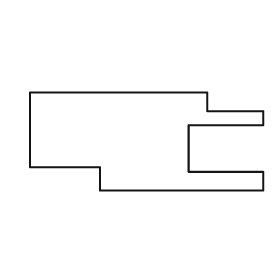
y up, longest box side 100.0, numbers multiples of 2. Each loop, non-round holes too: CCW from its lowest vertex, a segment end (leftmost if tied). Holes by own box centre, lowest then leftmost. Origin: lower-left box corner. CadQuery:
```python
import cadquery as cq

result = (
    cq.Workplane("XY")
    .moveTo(30.0, 0.0)
    .lineTo(100.0, 0.0)
    .lineTo(100.0, 8.0)
    .lineTo(68.0, 8.0)
    .lineTo(68.0, 28.0)
    .lineTo(100.0, 28.0)
    .lineTo(100.0, 34.0)
    .lineTo(76.0, 34.0)
    .lineTo(76.0, 42.0)
    .lineTo(0.0, 42.0)
    .lineTo(0.0, 10.0)
    .lineTo(30.0, 10.0)
    .close()
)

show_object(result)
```